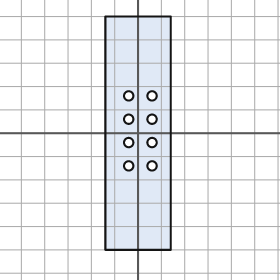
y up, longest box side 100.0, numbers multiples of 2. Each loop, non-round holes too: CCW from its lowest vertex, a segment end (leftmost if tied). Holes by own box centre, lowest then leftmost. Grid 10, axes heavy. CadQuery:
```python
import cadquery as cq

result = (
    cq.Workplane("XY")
    .moveTo(-14.0, -50.0)
    .lineTo(14.0, -50.0)
    .lineTo(14.0, 50.0)
    .lineTo(-14.0, 50.0)
    .close()
    .moveTo(-4.0, -14.0)
    .circle(2.0)
    .moveTo(6.0, -14.0)
    .circle(2.0)
    .moveTo(-4.0, -4.0)
    .circle(2.0)
    .moveTo(6.0, -4.0)
    .circle(2.0)
    .moveTo(-4.0, 6.0)
    .circle(2.0)
    .moveTo(6.0, 6.0)
    .circle(2.0)
    .moveTo(-4.0, 16.0)
    .circle(2.0)
    .moveTo(6.0, 16.0)
    .circle(2.0)
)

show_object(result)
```